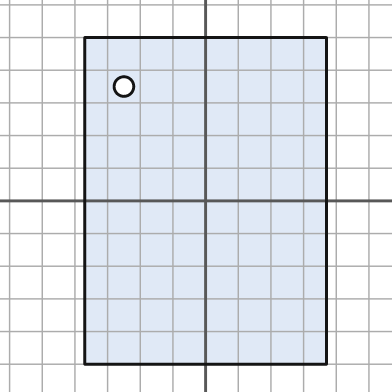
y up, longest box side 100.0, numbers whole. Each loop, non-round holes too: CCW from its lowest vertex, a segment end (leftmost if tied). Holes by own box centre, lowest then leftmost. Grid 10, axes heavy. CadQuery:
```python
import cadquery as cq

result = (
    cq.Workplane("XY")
    .moveTo(-37.0, -50.0)
    .lineTo(37.0, -50.0)
    .lineTo(37.0, 50.0)
    .lineTo(-37.0, 50.0)
    .close()
    .moveTo(-25.0, 35.0)
    .circle(3.0)
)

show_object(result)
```